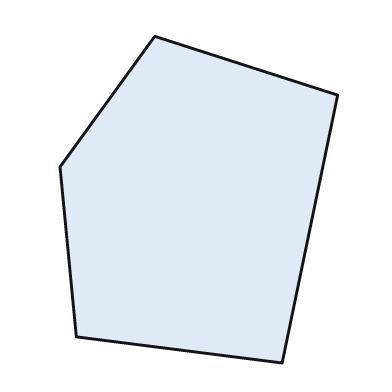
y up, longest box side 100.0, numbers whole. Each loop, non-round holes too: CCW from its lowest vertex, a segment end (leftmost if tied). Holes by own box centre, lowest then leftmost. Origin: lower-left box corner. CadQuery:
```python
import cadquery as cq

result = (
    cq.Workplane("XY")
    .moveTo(68.0, 0.0)
    .lineTo(85.0, 82.0)
    .lineTo(29.0, 100.0)
    .lineTo(0.0, 60.0)
    .lineTo(5.0, 8.0)
    .close()
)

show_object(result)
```